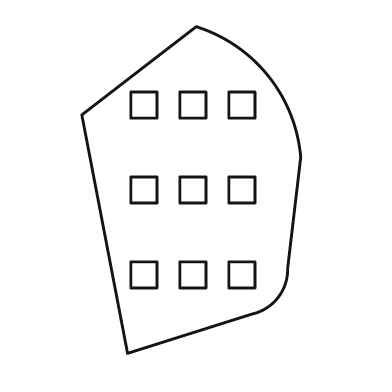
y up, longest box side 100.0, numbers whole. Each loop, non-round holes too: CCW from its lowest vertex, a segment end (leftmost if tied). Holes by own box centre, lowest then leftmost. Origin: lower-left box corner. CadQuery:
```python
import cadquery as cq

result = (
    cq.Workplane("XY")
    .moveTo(14.0, 0.0)
    .lineTo(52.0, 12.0)
    .threePointArc((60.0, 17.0), (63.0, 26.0))
    .lineTo(67.0, 60.0)
    .threePointArc((57.0, 85.0), (35.0, 100.0))
    .lineTo(0.0, 73.0)
    .close()
    .moveTo(15.0, 20.0)
    .lineTo(23.0, 20.0)
    .lineTo(23.0, 28.0)
    .lineTo(15.0, 28.0)
    .close()
    .moveTo(30.0, 20.0)
    .lineTo(38.0, 20.0)
    .lineTo(38.0, 28.0)
    .lineTo(30.0, 28.0)
    .close()
    .moveTo(45.0, 20.0)
    .lineTo(53.0, 20.0)
    .lineTo(53.0, 28.0)
    .lineTo(45.0, 28.0)
    .close()
    .moveTo(15.0, 46.0)
    .lineTo(23.0, 46.0)
    .lineTo(23.0, 54.0)
    .lineTo(15.0, 54.0)
    .close()
    .moveTo(30.0, 46.0)
    .lineTo(38.0, 46.0)
    .lineTo(38.0, 54.0)
    .lineTo(30.0, 54.0)
    .close()
    .moveTo(45.0, 46.0)
    .lineTo(53.0, 46.0)
    .lineTo(53.0, 54.0)
    .lineTo(45.0, 54.0)
    .close()
    .moveTo(15.0, 72.0)
    .lineTo(23.0, 72.0)
    .lineTo(23.0, 80.0)
    .lineTo(15.0, 80.0)
    .close()
    .moveTo(30.0, 72.0)
    .lineTo(38.0, 72.0)
    .lineTo(38.0, 80.0)
    .lineTo(30.0, 80.0)
    .close()
    .moveTo(45.0, 72.0)
    .lineTo(53.0, 72.0)
    .lineTo(53.0, 80.0)
    .lineTo(45.0, 80.0)
    .close()
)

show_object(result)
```